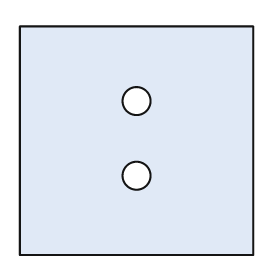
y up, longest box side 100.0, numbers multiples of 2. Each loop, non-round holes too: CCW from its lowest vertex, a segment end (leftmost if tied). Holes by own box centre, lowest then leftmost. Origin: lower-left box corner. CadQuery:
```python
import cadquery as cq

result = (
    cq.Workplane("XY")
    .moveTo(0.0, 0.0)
    .lineTo(100.0, 0.0)
    .lineTo(100.0, 98.0)
    .lineTo(0.0, 98.0)
    .close()
    .moveTo(50.0, 34.0)
    .circle(6.0)
    .moveTo(50.0, 66.0)
    .circle(6.0)
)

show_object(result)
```